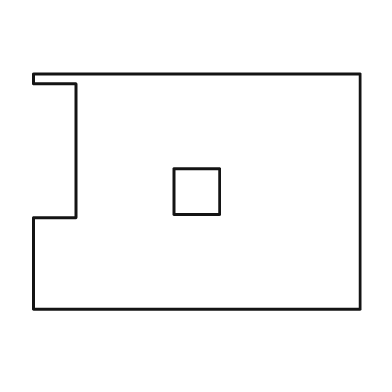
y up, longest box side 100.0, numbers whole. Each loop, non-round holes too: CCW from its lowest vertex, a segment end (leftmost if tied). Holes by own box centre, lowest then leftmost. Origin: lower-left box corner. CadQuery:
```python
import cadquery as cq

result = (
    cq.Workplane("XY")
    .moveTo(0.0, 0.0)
    .lineTo(100.0, 0.0)
    .lineTo(100.0, 72.0)
    .lineTo(0.0, 72.0)
    .lineTo(0.0, 69.0)
    .lineTo(13.0, 69.0)
    .lineTo(13.0, 28.0)
    .lineTo(0.0, 28.0)
    .close()
    .moveTo(43.0, 29.0)
    .lineTo(57.0, 29.0)
    .lineTo(57.0, 43.0)
    .lineTo(43.0, 43.0)
    .close()
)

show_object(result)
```